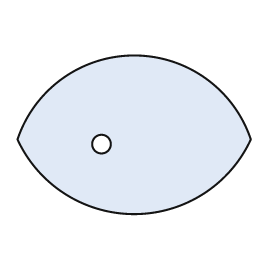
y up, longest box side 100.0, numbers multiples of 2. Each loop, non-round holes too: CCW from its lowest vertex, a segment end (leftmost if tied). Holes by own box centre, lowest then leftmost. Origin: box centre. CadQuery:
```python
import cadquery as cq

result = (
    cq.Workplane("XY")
    .moveTo(-50.0, -2.0)
    .threePointArc((0.0, -34.0), (50.0, -2.0))
    .threePointArc((0.0, 34.0), (-50.0, -2.0))
    .close()
    .moveTo(-14.0, -4.0)
    .circle(4.0)
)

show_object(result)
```